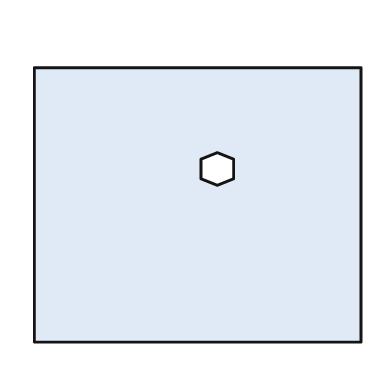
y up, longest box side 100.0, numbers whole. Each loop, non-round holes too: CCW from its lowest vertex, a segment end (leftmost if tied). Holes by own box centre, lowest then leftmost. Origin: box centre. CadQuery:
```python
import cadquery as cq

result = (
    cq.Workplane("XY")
    .moveTo(-50.0, -42.0)
    .lineTo(50.0, -42.0)
    .lineTo(50.0, 42.0)
    .lineTo(-50.0, 42.0)
    .close()
    .moveTo(6.0, 6.0)
    .lineTo(11.0, 8.0)
    .lineTo(11.0, 14.0)
    .lineTo(6.0, 16.0)
    .lineTo(1.0, 14.0)
    .lineTo(1.0, 8.0)
    .close()
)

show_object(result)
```